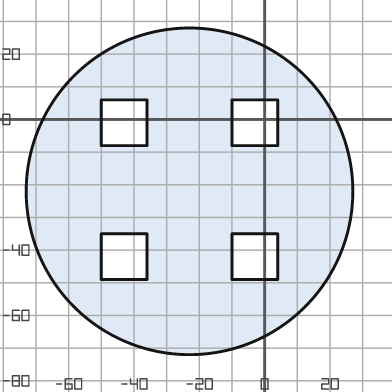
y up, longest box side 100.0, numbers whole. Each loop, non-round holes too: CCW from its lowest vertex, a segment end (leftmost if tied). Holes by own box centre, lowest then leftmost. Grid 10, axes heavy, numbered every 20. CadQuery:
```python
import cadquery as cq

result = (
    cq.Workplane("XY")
    .moveTo(-23.0, -22.0)
    .circle(50.0)
    .moveTo(-50.0, -49.0)
    .lineTo(-36.0, -49.0)
    .lineTo(-36.0, -35.0)
    .lineTo(-50.0, -35.0)
    .close()
    .moveTo(-10.0, -49.0)
    .lineTo(4.0, -49.0)
    .lineTo(4.0, -35.0)
    .lineTo(-10.0, -35.0)
    .close()
    .moveTo(-50.0, -8.0)
    .lineTo(-36.0, -8.0)
    .lineTo(-36.0, 6.0)
    .lineTo(-50.0, 6.0)
    .close()
    .moveTo(-10.0, -8.0)
    .lineTo(4.0, -8.0)
    .lineTo(4.0, 6.0)
    .lineTo(-10.0, 6.0)
    .close()
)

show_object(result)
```